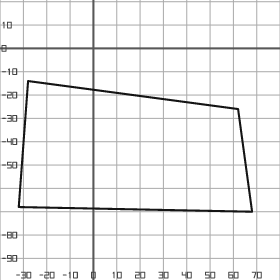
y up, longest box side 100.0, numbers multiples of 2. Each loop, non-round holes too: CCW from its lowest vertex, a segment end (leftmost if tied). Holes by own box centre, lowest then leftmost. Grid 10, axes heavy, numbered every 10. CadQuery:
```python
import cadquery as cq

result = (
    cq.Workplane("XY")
    .moveTo(68.0, -70.0)
    .lineTo(62.0, -26.0)
    .lineTo(-28.0, -14.0)
    .lineTo(-32.0, -68.0)
    .close()
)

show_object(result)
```